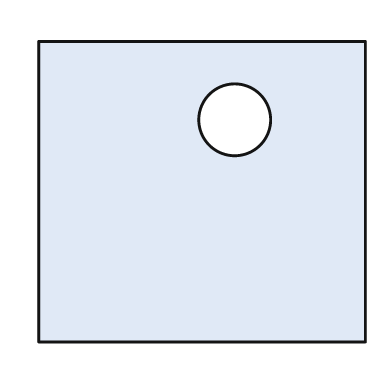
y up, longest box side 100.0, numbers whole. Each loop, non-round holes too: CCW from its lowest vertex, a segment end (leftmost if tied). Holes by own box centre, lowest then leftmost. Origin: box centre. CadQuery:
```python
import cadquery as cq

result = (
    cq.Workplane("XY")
    .moveTo(-50.0, -46.0)
    .lineTo(50.0, -46.0)
    .lineTo(50.0, 46.0)
    .lineTo(-50.0, 46.0)
    .close()
    .moveTo(10.0, 22.0)
    .circle(11.0)
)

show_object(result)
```